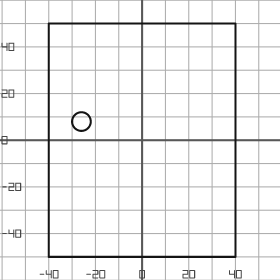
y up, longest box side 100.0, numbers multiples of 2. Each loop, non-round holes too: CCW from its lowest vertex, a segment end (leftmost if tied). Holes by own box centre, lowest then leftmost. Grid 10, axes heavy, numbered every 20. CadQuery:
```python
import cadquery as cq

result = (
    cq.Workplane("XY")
    .moveTo(-40.0, -50.0)
    .lineTo(40.0, -50.0)
    .lineTo(40.0, 50.0)
    .lineTo(-40.0, 50.0)
    .close()
    .moveTo(-26.0, 8.0)
    .circle(4.0)
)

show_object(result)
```